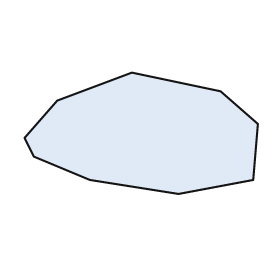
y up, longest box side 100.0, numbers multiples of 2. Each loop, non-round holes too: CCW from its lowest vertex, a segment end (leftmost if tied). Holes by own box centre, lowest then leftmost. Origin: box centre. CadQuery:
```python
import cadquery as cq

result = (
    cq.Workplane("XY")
    .moveTo(16.0, -26.0)
    .lineTo(48.0, -20.0)
    .lineTo(50.0, 4.0)
    .lineTo(34.0, 18.0)
    .lineTo(-4.0, 26.0)
    .lineTo(-36.0, 14.0)
    .lineTo(-50.0, -2.0)
    .lineTo(-46.0, -10.0)
    .lineTo(-22.0, -20.0)
    .close()
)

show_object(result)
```